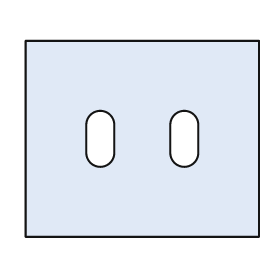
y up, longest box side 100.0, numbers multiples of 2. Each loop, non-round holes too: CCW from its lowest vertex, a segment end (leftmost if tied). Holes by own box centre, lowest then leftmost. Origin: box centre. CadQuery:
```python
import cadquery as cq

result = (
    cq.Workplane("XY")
    .moveTo(-50.0, -42.0)
    .lineTo(50.0, -42.0)
    .lineTo(50.0, 42.0)
    .lineTo(-50.0, 42.0)
    .close()
    .moveTo(-24.0, -6.0)
    .threePointArc((-18.0, -12.0), (-12.0, -6.0))
    .lineTo(-12.0, 6.0)
    .threePointArc((-18.0, 12.0), (-24.0, 6.0))
    .close()
    .moveTo(12.0, -6.0)
    .threePointArc((18.0, -12.0), (24.0, -6.0))
    .lineTo(24.0, 6.0)
    .threePointArc((18.0, 12.0), (12.0, 6.0))
    .close()
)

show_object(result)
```